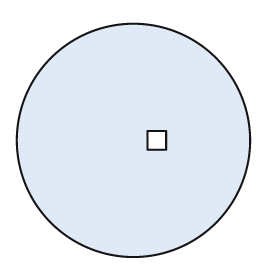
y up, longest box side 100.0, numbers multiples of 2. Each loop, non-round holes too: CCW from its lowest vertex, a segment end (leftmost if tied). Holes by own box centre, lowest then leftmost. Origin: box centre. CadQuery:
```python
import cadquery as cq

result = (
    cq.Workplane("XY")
    .moveTo(0.0, 0.0)
    .circle(50.0)
    .moveTo(6.0, -4.0)
    .lineTo(14.0, -4.0)
    .lineTo(14.0, 4.0)
    .lineTo(6.0, 4.0)
    .close()
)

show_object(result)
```